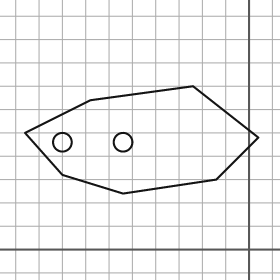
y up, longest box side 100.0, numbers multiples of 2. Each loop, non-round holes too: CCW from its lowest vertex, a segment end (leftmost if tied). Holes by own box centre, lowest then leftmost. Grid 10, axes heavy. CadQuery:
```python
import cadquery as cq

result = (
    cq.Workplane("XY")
    .moveTo(-54.0, 24.0)
    .lineTo(-14.0, 30.0)
    .lineTo(4.0, 48.0)
    .lineTo(-24.0, 70.0)
    .lineTo(-68.0, 64.0)
    .lineTo(-96.0, 50.0)
    .lineTo(-80.0, 32.0)
    .close()
    .moveTo(-80.0, 46.0)
    .circle(4.0)
    .moveTo(-54.0, 46.0)
    .circle(4.0)
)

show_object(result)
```